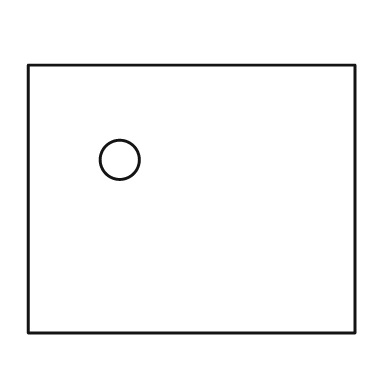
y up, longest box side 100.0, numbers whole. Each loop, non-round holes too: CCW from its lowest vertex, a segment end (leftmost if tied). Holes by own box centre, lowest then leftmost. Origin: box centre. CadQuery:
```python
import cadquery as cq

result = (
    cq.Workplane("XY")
    .moveTo(-50.0, -41.0)
    .lineTo(50.0, -41.0)
    .lineTo(50.0, 41.0)
    .lineTo(-50.0, 41.0)
    .close()
    .moveTo(-22.0, 12.0)
    .circle(6.0)
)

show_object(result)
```